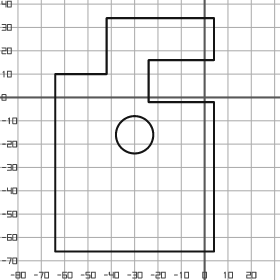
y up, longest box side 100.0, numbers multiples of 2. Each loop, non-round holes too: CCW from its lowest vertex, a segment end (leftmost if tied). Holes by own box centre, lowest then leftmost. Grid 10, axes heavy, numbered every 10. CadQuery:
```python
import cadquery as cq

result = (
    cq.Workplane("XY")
    .moveTo(-64.0, -66.0)
    .lineTo(4.0, -66.0)
    .lineTo(4.0, -2.0)
    .lineTo(-24.0, -2.0)
    .lineTo(-24.0, 16.0)
    .lineTo(4.0, 16.0)
    .lineTo(4.0, 34.0)
    .lineTo(-42.0, 34.0)
    .lineTo(-42.0, 10.0)
    .lineTo(-64.0, 10.0)
    .close()
    .moveTo(-30.0, -16.0)
    .circle(8.0)
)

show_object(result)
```